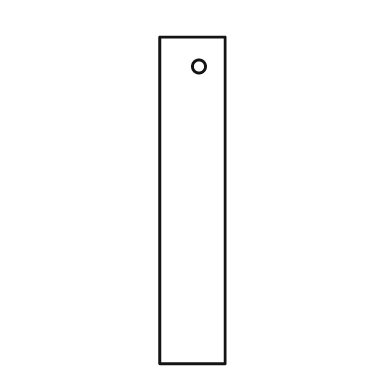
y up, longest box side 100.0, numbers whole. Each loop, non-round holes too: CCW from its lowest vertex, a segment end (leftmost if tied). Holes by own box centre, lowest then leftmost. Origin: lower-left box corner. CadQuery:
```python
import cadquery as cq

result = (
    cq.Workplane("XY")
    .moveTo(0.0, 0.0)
    .lineTo(20.0, 0.0)
    .lineTo(20.0, 100.0)
    .lineTo(0.0, 100.0)
    .close()
    .moveTo(12.0, 91.0)
    .circle(2.0)
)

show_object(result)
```